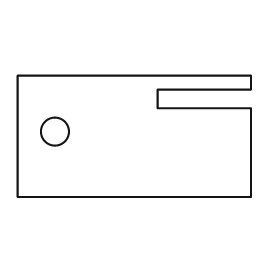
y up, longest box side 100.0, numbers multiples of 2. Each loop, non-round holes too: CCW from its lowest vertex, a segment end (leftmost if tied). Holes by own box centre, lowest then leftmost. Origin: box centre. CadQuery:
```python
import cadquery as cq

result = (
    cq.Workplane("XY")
    .moveTo(-50.0, -26.0)
    .lineTo(50.0, -26.0)
    .lineTo(50.0, 12.0)
    .lineTo(10.0, 12.0)
    .lineTo(10.0, 20.0)
    .lineTo(50.0, 20.0)
    .lineTo(50.0, 26.0)
    .lineTo(-50.0, 26.0)
    .close()
    .moveTo(-34.0, 2.0)
    .circle(6.0)
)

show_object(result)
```